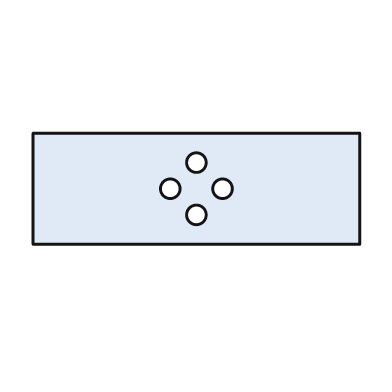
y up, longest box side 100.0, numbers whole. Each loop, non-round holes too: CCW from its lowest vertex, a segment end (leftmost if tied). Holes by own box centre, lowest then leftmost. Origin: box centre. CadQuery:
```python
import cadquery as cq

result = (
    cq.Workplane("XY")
    .moveTo(-50.0, -17.0)
    .lineTo(50.0, -17.0)
    .lineTo(50.0, 17.0)
    .lineTo(-50.0, 17.0)
    .close()
    .moveTo(0.0, -8.0)
    .circle(3.0)
    .moveTo(-8.0, 0.0)
    .circle(3.0)
    .moveTo(8.0, 0.0)
    .circle(3.0)
    .moveTo(0.0, 8.0)
    .circle(3.0)
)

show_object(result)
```